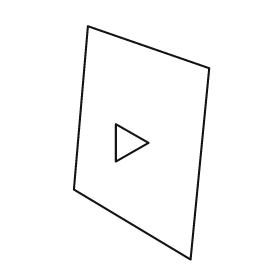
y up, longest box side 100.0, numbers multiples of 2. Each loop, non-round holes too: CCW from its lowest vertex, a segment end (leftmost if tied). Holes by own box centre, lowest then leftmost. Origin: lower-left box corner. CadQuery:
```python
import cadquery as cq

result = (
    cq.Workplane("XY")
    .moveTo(50.0, 0.0)
    .lineTo(58.0, 82.0)
    .lineTo(6.0, 100.0)
    .lineTo(0.0, 30.0)
    .close()
    .moveTo(18.0, 42.0)
    .lineTo(32.0, 50.0)
    .lineTo(18.0, 58.0)
    .close()
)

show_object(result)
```